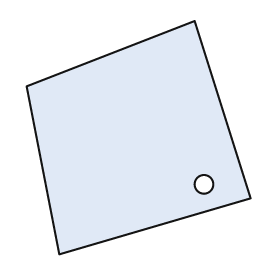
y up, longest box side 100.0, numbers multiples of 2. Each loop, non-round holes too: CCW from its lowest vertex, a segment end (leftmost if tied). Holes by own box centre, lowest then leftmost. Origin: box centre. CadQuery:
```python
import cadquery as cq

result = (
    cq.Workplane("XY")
    .moveTo(-34.0, -50.0)
    .lineTo(48.0, -26.0)
    .lineTo(24.0, 50.0)
    .lineTo(-48.0, 22.0)
    .close()
    .moveTo(28.0, -20.0)
    .circle(4.0)
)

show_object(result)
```